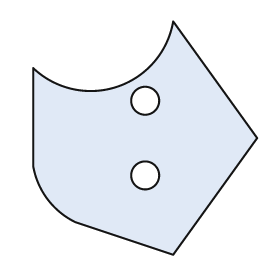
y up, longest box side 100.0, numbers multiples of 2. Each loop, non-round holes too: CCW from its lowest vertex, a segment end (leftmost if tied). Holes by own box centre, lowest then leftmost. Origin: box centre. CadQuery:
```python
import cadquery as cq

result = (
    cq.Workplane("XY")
    .moveTo(12.0, -50.0)
    .lineTo(48.0, 0.0)
    .lineTo(12.0, 50.0)
    .threePointArc((-12.0, 22.0), (-48.0, 30.0))
    .lineTo(-48.0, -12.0)
    .threePointArc((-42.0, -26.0), (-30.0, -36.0))
    .close()
    .moveTo(0.0, -16.0)
    .circle(6.0)
    .moveTo(0.0, 16.0)
    .circle(6.0)
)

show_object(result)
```